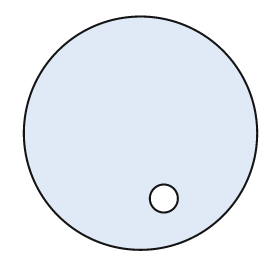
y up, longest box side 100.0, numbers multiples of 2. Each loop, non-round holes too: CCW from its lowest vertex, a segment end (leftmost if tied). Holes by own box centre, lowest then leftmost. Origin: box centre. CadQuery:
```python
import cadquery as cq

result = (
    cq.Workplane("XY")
    .moveTo(0.0, 0.0)
    .circle(50.0)
    .moveTo(10.0, -28.0)
    .circle(6.0)
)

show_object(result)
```